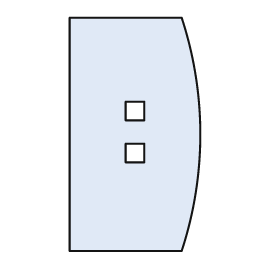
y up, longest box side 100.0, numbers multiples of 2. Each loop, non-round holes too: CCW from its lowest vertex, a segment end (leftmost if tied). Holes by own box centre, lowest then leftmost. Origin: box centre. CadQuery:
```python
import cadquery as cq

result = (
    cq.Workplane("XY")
    .moveTo(-28.0, -50.0)
    .lineTo(20.0, -50.0)
    .threePointArc((28.0, 0.0), (20.0, 50.0))
    .lineTo(-28.0, 50.0)
    .close()
    .moveTo(-4.0, -12.0)
    .lineTo(4.0, -12.0)
    .lineTo(4.0, -4.0)
    .lineTo(-4.0, -4.0)
    .close()
    .moveTo(-4.0, 6.0)
    .lineTo(4.0, 6.0)
    .lineTo(4.0, 14.0)
    .lineTo(-4.0, 14.0)
    .close()
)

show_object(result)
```